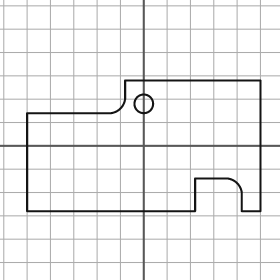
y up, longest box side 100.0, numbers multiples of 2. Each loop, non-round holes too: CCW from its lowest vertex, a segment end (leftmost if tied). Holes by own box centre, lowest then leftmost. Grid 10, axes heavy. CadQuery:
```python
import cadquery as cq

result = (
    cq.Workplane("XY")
    .moveTo(-50.0, -28.0)
    .lineTo(22.0, -28.0)
    .lineTo(22.0, -14.0)
    .lineTo(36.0, -14.0)
    .threePointArc((40.0, -16.0), (42.0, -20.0))
    .lineTo(42.0, -28.0)
    .lineTo(50.0, -28.0)
    .lineTo(50.0, 28.0)
    .lineTo(-8.0, 28.0)
    .lineTo(-8.0, 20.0)
    .threePointArc((-10.0, 16.0), (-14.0, 14.0))
    .lineTo(-50.0, 14.0)
    .close()
    .moveTo(0.0, 18.0)
    .circle(4.0)
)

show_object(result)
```